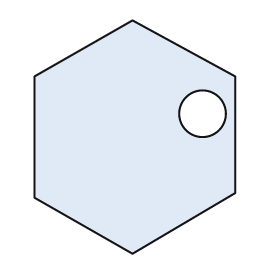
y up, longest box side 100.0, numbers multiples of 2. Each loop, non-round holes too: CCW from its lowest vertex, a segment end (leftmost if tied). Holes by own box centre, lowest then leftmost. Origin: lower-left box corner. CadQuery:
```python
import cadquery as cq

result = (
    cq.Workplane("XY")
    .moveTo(42.0, 0.0)
    .lineTo(86.0, 26.0)
    .lineTo(86.0, 76.0)
    .lineTo(42.0, 100.0)
    .lineTo(0.0, 76.0)
    .lineTo(0.0, 24.0)
    .close()
    .moveTo(72.0, 60.0)
    .circle(10.0)
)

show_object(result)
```